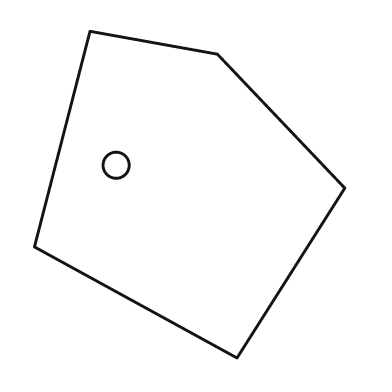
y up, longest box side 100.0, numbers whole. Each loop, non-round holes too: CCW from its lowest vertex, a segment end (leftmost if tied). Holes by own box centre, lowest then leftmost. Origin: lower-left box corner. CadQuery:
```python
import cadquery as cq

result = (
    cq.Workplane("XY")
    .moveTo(62.0, 0.0)
    .lineTo(95.0, 52.0)
    .lineTo(56.0, 93.0)
    .lineTo(17.0, 100.0)
    .lineTo(0.0, 34.0)
    .close()
    .moveTo(25.0, 59.0)
    .circle(4.0)
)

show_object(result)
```